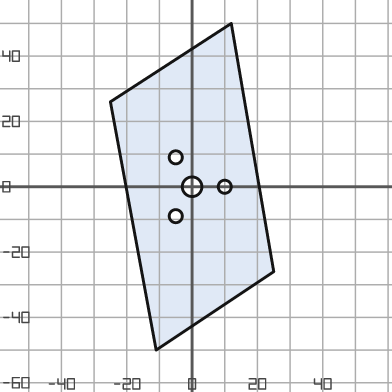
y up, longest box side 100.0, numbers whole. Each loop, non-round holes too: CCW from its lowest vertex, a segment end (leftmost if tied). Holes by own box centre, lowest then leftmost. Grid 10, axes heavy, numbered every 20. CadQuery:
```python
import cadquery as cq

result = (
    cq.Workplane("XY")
    .moveTo(-11.0, -50.0)
    .lineTo(25.0, -26.0)
    .lineTo(12.0, 50.0)
    .lineTo(-25.0, 26.0)
    .close()
    .moveTo(-5.0, -9.0)
    .circle(2.0)
    .moveTo(0.0, 0.0)
    .circle(3.0)
    .moveTo(10.0, 0.0)
    .circle(2.0)
    .moveTo(-5.0, 9.0)
    .circle(2.0)
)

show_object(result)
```